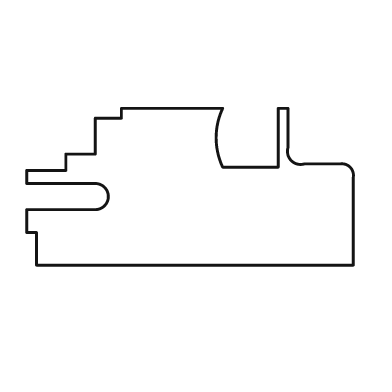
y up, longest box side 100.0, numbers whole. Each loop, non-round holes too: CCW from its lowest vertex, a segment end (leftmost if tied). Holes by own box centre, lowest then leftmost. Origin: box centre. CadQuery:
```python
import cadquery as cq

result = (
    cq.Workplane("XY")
    .moveTo(-47.0, -24.0)
    .lineTo(50.0, -24.0)
    .lineTo(50.0, 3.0)
    .threePointArc((49.0, 6.0), (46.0, 7.0))
    .lineTo(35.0, 7.0)
    .threePointArc((31.0, 8.0), (30.0, 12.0))
    .lineTo(30.0, 24.0)
    .lineTo(27.0, 24.0)
    .lineTo(27.0, 6.0)
    .lineTo(10.0, 6.0)
    .threePointArc((8.0, 15.0), (10.0, 24.0))
    .lineTo(-21.0, 24.0)
    .lineTo(-21.0, 21.0)
    .lineTo(-29.0, 21.0)
    .lineTo(-29.0, 10.0)
    .lineTo(-38.0, 10.0)
    .lineTo(-38.0, 5.0)
    .lineTo(-50.0, 5.0)
    .lineTo(-50.0, 1.0)
    .lineTo(-29.0, 1.0)
    .threePointArc((-25.0, -3.0), (-29.0, -7.0))
    .lineTo(-50.0, -7.0)
    .lineTo(-50.0, -14.0)
    .lineTo(-47.0, -14.0)
    .close()
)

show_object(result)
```